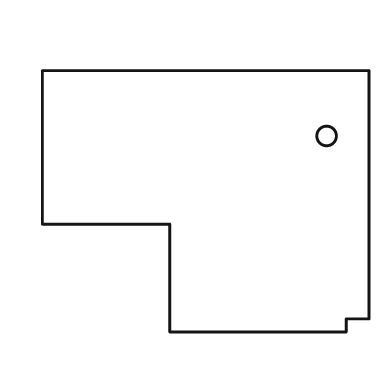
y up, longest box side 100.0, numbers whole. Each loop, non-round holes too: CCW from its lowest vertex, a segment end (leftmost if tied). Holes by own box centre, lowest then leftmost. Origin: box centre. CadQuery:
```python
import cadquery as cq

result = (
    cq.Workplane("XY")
    .moveTo(-11.0, -40.0)
    .lineTo(43.0, -40.0)
    .lineTo(43.0, -36.0)
    .lineTo(50.0, -36.0)
    .lineTo(50.0, 40.0)
    .lineTo(-50.0, 40.0)
    .lineTo(-50.0, -7.0)
    .lineTo(-11.0, -7.0)
    .close()
    .moveTo(37.0, 20.0)
    .circle(3.0)
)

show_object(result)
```